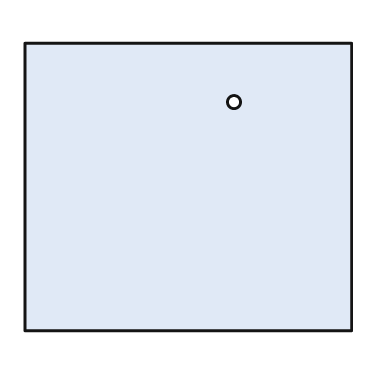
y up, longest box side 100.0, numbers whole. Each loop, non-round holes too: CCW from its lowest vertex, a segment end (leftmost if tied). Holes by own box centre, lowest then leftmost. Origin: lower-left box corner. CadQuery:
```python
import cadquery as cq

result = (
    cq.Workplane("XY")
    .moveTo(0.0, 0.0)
    .lineTo(100.0, 0.0)
    .lineTo(100.0, 88.0)
    .lineTo(0.0, 88.0)
    .close()
    .moveTo(64.0, 70.0)
    .circle(2.0)
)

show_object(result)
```